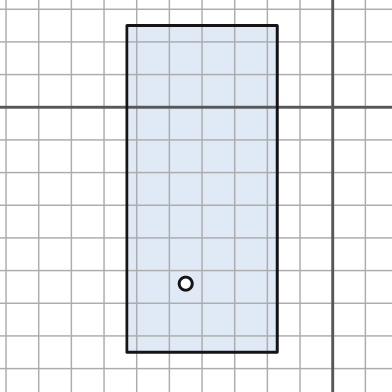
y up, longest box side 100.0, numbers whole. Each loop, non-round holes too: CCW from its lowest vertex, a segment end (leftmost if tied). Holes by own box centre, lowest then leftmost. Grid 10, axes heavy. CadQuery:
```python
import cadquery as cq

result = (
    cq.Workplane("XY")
    .moveTo(-63.0, -75.0)
    .lineTo(-17.0, -75.0)
    .lineTo(-17.0, 25.0)
    .lineTo(-63.0, 25.0)
    .close()
    .moveTo(-45.0, -54.0)
    .circle(2.0)
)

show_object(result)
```